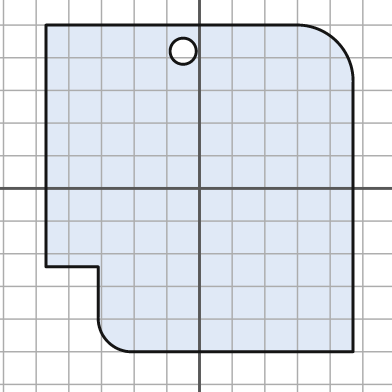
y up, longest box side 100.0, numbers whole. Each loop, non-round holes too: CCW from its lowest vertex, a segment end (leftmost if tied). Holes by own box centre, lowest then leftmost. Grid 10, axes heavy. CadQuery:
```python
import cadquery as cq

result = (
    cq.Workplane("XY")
    .moveTo(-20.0, -50.0)
    .lineTo(47.0, -50.0)
    .lineTo(47.0, 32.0)
    .threePointArc((42.0, 45.0), (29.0, 50.0))
    .lineTo(-47.0, 50.0)
    .lineTo(-47.0, -24.0)
    .lineTo(-31.0, -24.0)
    .lineTo(-31.0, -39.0)
    .threePointArc((-28.0, -47.0), (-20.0, -50.0))
    .close()
    .moveTo(-5.0, 42.0)
    .circle(4.0)
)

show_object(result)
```